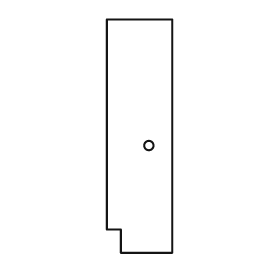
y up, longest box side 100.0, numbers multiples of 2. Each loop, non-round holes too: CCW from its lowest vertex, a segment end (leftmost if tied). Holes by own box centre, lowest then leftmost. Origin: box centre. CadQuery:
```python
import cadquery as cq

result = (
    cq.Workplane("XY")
    .moveTo(-8.0, -50.0)
    .lineTo(14.0, -50.0)
    .lineTo(14.0, 50.0)
    .lineTo(-14.0, 50.0)
    .lineTo(-14.0, -40.0)
    .lineTo(-8.0, -40.0)
    .close()
    .moveTo(4.0, -4.0)
    .circle(2.0)
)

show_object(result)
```